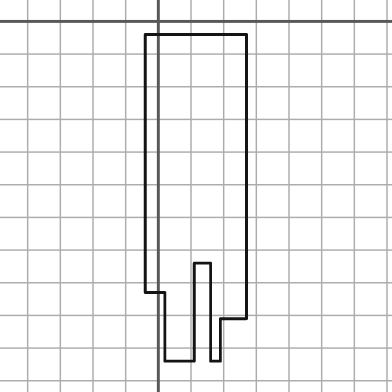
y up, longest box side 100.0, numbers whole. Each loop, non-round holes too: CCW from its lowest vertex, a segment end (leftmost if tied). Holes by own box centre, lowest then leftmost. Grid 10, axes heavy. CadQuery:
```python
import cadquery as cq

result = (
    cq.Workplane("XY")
    .moveTo(2.0, -104.0)
    .lineTo(11.0, -104.0)
    .lineTo(11.0, -74.0)
    .lineTo(16.0, -74.0)
    .lineTo(16.0, -104.0)
    .lineTo(19.0, -104.0)
    .lineTo(19.0, -91.0)
    .lineTo(27.0, -91.0)
    .lineTo(27.0, -4.0)
    .lineTo(-4.0, -4.0)
    .lineTo(-4.0, -83.0)
    .lineTo(2.0, -83.0)
    .close()
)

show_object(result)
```